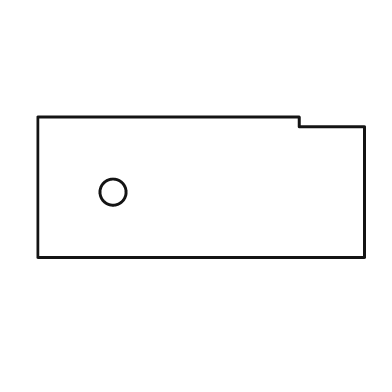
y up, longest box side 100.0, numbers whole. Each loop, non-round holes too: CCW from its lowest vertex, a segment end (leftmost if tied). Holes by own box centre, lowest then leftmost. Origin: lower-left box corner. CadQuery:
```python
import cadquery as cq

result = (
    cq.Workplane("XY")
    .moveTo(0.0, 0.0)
    .lineTo(100.0, 0.0)
    .lineTo(100.0, 40.0)
    .lineTo(80.0, 40.0)
    .lineTo(80.0, 43.0)
    .lineTo(0.0, 43.0)
    .close()
    .moveTo(23.0, 20.0)
    .circle(4.0)
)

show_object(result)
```